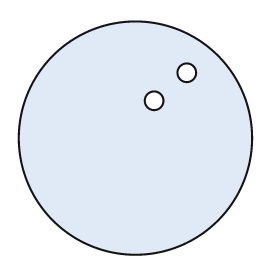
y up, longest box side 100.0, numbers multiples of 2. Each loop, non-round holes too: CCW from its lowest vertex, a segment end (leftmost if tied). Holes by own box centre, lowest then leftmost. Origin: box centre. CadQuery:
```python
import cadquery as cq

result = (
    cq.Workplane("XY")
    .moveTo(0.0, 0.0)
    .circle(50.0)
    .moveTo(8.0, 16.0)
    .circle(4.0)
    .moveTo(22.0, 28.0)
    .circle(4.0)
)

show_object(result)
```